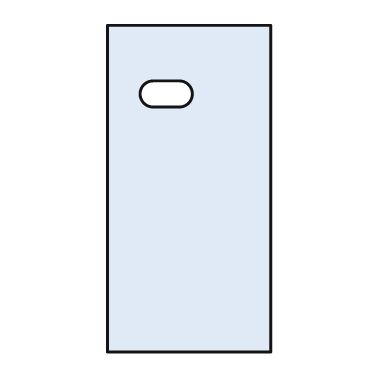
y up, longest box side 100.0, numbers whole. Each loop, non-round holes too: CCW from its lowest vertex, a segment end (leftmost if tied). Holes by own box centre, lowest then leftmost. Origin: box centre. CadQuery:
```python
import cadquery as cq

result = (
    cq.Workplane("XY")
    .moveTo(-25.0, -50.0)
    .lineTo(25.0, -50.0)
    .lineTo(25.0, 50.0)
    .lineTo(-25.0, 50.0)
    .close()
    .moveTo(-11.0, 25.0)
    .lineTo(-3.0, 25.0)
    .threePointArc((1.0, 29.0), (-3.0, 33.0))
    .lineTo(-11.0, 33.0)
    .threePointArc((-15.0, 29.0), (-11.0, 25.0))
    .close()
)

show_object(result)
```